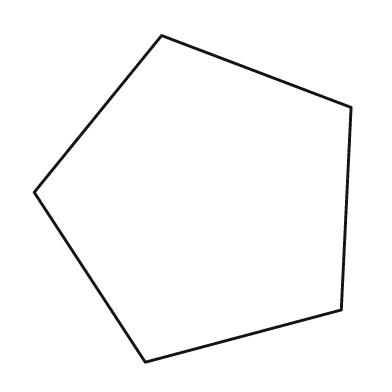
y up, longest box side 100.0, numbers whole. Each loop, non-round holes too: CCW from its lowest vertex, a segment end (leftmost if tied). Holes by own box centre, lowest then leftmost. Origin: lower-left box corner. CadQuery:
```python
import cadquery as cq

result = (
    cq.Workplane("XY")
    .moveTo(34.0, 0.0)
    .lineTo(94.0, 16.0)
    .lineTo(97.0, 78.0)
    .lineTo(39.0, 100.0)
    .lineTo(0.0, 52.0)
    .close()
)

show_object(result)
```